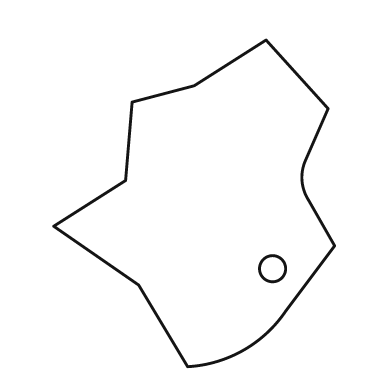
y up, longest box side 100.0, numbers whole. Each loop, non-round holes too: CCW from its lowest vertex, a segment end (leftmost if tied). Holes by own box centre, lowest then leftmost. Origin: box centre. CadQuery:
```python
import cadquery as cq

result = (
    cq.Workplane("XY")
    .moveTo(-2.0, -50.0)
    .threePointArc((15.0, -45.0), (28.0, -33.0))
    .lineTo(43.0, -13.0)
    .lineTo(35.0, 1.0)
    .threePointArc((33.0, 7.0), (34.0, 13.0))
    .lineTo(41.0, 29.0)
    .lineTo(22.0, 50.0)
    .lineTo(0.0, 36.0)
    .lineTo(-19.0, 31.0)
    .lineTo(-21.0, 7.0)
    .lineTo(-43.0, -7.0)
    .lineTo(-17.0, -25.0)
    .close()
    .moveTo(24.0, -20.0)
    .circle(4.0)
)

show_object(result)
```